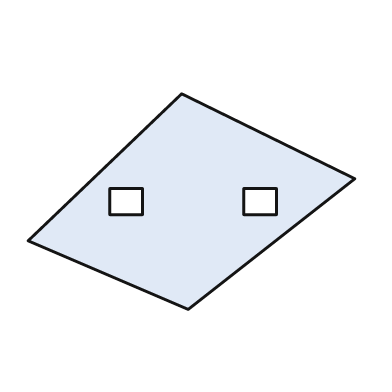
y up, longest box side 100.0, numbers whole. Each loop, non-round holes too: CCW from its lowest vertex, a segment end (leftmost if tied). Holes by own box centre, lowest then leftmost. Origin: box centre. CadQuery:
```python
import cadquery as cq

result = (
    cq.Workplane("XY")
    .moveTo(-1.0, -33.0)
    .lineTo(50.0, 7.0)
    .lineTo(-3.0, 33.0)
    .lineTo(-50.0, -12.0)
    .close()
    .moveTo(-25.0, -4.0)
    .lineTo(-15.0, -4.0)
    .lineTo(-15.0, 4.0)
    .lineTo(-25.0, 4.0)
    .close()
    .moveTo(16.0, -4.0)
    .lineTo(26.0, -4.0)
    .lineTo(26.0, 4.0)
    .lineTo(16.0, 4.0)
    .close()
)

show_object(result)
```